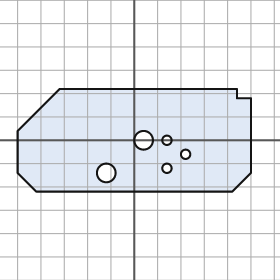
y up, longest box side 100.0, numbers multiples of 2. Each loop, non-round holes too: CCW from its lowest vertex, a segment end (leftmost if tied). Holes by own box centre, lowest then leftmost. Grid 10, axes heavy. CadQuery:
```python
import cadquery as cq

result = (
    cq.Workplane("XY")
    .moveTo(-42.0, -22.0)
    .lineTo(42.0, -22.0)
    .lineTo(50.0, -14.0)
    .lineTo(50.0, 18.0)
    .lineTo(44.0, 18.0)
    .lineTo(44.0, 22.0)
    .lineTo(-32.0, 22.0)
    .lineTo(-50.0, 4.0)
    .lineTo(-50.0, -14.0)
    .close()
    .moveTo(-12.0, -14.0)
    .circle(4.0)
    .moveTo(14.0, -12.0)
    .circle(2.0)
    .moveTo(22.0, -6.0)
    .circle(2.0)
    .moveTo(4.0, 0.0)
    .circle(4.0)
    .moveTo(14.0, 0.0)
    .circle(2.0)
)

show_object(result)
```